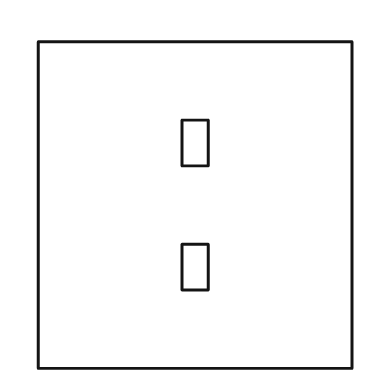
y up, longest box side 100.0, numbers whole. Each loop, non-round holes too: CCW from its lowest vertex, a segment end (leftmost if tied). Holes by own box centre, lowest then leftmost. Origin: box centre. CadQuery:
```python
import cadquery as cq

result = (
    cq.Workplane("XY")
    .moveTo(-48.0, -50.0)
    .lineTo(48.0, -50.0)
    .lineTo(48.0, 50.0)
    .lineTo(-48.0, 50.0)
    .close()
    .moveTo(-4.0, -26.0)
    .lineTo(4.0, -26.0)
    .lineTo(4.0, -12.0)
    .lineTo(-4.0, -12.0)
    .close()
    .moveTo(-4.0, 12.0)
    .lineTo(4.0, 12.0)
    .lineTo(4.0, 26.0)
    .lineTo(-4.0, 26.0)
    .close()
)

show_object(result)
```